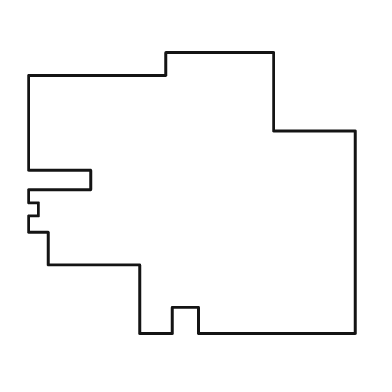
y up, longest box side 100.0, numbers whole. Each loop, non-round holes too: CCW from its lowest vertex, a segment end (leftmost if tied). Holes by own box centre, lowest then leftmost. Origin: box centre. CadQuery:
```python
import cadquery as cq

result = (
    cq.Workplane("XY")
    .moveTo(-16.0, -43.0)
    .lineTo(-6.0, -43.0)
    .lineTo(-6.0, -35.0)
    .lineTo(2.0, -35.0)
    .lineTo(2.0, -43.0)
    .lineTo(50.0, -43.0)
    .lineTo(50.0, 19.0)
    .lineTo(25.0, 19.0)
    .lineTo(25.0, 43.0)
    .lineTo(-8.0, 43.0)
    .lineTo(-8.0, 36.0)
    .lineTo(-50.0, 36.0)
    .lineTo(-50.0, 7.0)
    .lineTo(-31.0, 7.0)
    .lineTo(-31.0, 1.0)
    .lineTo(-50.0, 1.0)
    .lineTo(-50.0, -3.0)
    .lineTo(-47.0, -3.0)
    .lineTo(-47.0, -7.0)
    .lineTo(-50.0, -7.0)
    .lineTo(-50.0, -12.0)
    .lineTo(-44.0, -12.0)
    .lineTo(-44.0, -22.0)
    .lineTo(-16.0, -22.0)
    .close()
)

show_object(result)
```